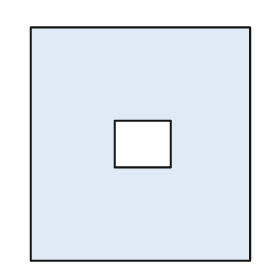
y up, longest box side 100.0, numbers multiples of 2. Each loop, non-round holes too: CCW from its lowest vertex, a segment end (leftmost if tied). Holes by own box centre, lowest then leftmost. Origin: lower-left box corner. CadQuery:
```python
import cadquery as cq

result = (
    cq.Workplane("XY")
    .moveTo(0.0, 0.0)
    .lineTo(94.0, 0.0)
    .lineTo(94.0, 100.0)
    .lineTo(0.0, 100.0)
    .close()
    .moveTo(36.0, 40.0)
    .lineTo(60.0, 40.0)
    .lineTo(60.0, 60.0)
    .lineTo(36.0, 60.0)
    .close()
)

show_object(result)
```